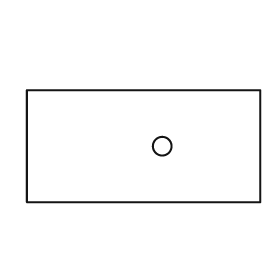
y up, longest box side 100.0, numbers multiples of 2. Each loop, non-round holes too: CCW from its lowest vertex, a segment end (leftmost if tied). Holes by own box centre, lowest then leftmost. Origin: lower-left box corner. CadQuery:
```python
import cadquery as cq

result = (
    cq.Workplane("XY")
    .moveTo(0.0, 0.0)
    .lineTo(100.0, 0.0)
    .lineTo(100.0, 48.0)
    .lineTo(0.0, 48.0)
    .close()
    .moveTo(58.0, 24.0)
    .circle(4.0)
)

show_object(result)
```